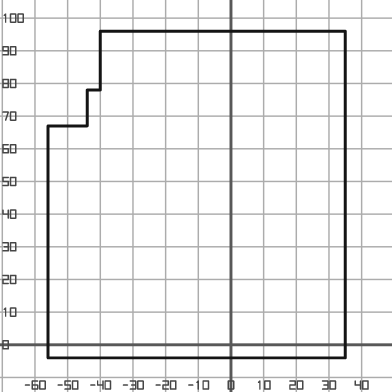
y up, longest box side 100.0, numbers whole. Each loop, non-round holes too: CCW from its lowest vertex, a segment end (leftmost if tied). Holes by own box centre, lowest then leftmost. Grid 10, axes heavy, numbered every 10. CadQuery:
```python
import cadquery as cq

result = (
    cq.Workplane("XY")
    .moveTo(-56.0, -4.0)
    .lineTo(35.0, -4.0)
    .lineTo(35.0, 96.0)
    .lineTo(-40.0, 96.0)
    .lineTo(-40.0, 78.0)
    .lineTo(-44.0, 78.0)
    .lineTo(-44.0, 67.0)
    .lineTo(-56.0, 67.0)
    .close()
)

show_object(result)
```